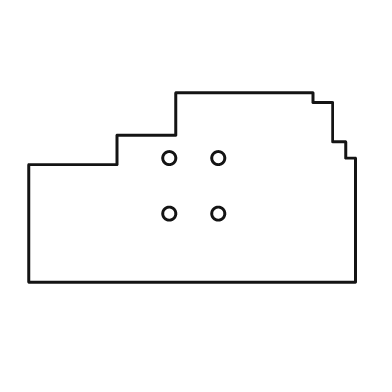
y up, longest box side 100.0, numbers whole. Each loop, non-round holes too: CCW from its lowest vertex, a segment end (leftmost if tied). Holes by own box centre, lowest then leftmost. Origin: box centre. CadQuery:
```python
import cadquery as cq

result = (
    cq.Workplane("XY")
    .moveTo(-50.0, -29.0)
    .lineTo(50.0, -29.0)
    .lineTo(50.0, 9.0)
    .lineTo(47.0, 9.0)
    .lineTo(47.0, 14.0)
    .lineTo(43.0, 14.0)
    .lineTo(43.0, 26.0)
    .lineTo(37.0, 26.0)
    .lineTo(37.0, 29.0)
    .lineTo(-5.0, 29.0)
    .lineTo(-5.0, 16.0)
    .lineTo(-23.0, 16.0)
    .lineTo(-23.0, 7.0)
    .lineTo(-50.0, 7.0)
    .close()
    .moveTo(-7.0, -8.0)
    .circle(2.0)
    .moveTo(8.0, -8.0)
    .circle(2.0)
    .moveTo(-7.0, 9.0)
    .circle(2.0)
    .moveTo(8.0, 9.0)
    .circle(2.0)
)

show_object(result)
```